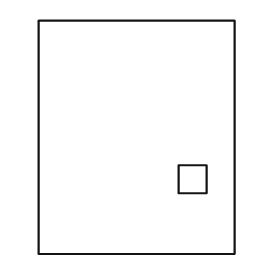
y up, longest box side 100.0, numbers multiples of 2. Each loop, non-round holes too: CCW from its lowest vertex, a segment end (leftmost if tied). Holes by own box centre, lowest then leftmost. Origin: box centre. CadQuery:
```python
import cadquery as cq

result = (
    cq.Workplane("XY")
    .moveTo(-42.0, -50.0)
    .lineTo(42.0, -50.0)
    .lineTo(42.0, 50.0)
    .lineTo(-42.0, 50.0)
    .close()
    .moveTo(18.0, -24.0)
    .lineTo(30.0, -24.0)
    .lineTo(30.0, -12.0)
    .lineTo(18.0, -12.0)
    .close()
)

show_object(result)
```